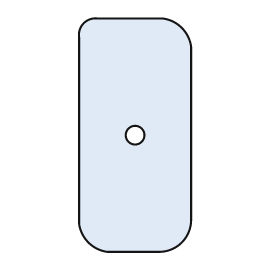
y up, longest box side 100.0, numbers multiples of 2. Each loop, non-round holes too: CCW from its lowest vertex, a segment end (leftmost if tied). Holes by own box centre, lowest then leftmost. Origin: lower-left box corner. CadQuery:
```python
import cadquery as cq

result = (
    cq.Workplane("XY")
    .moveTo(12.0, 0.0)
    .lineTo(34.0, 0.0)
    .threePointArc((44.0, 4.0), (48.0, 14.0))
    .lineTo(48.0, 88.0)
    .threePointArc((44.0, 96.0), (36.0, 100.0))
    .lineTo(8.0, 100.0)
    .threePointArc((2.0, 98.0), (0.0, 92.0))
    .lineTo(0.0, 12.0)
    .threePointArc((4.0, 4.0), (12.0, 0.0))
    .close()
    .moveTo(24.0, 50.0)
    .circle(4.0)
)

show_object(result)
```